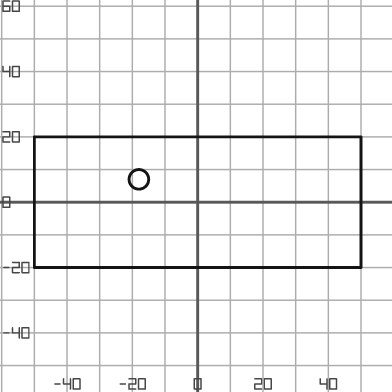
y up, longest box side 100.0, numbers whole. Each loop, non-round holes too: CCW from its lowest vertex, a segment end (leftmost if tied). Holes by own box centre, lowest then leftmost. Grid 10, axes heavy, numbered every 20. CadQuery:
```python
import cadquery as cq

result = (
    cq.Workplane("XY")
    .moveTo(-50.0, -20.0)
    .lineTo(50.0, -20.0)
    .lineTo(50.0, 20.0)
    .lineTo(-50.0, 20.0)
    .close()
    .moveTo(-18.0, 7.0)
    .circle(3.0)
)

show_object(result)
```